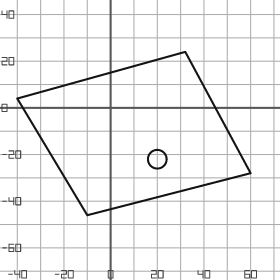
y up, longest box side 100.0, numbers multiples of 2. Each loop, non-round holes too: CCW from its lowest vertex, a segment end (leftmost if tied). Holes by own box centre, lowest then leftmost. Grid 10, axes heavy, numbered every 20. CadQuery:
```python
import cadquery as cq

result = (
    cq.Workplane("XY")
    .moveTo(-10.0, -46.0)
    .lineTo(60.0, -28.0)
    .lineTo(32.0, 24.0)
    .lineTo(-40.0, 4.0)
    .close()
    .moveTo(20.0, -22.0)
    .circle(4.0)
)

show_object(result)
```